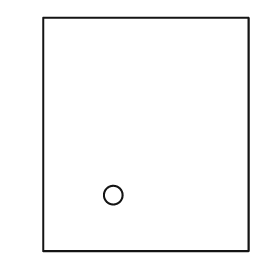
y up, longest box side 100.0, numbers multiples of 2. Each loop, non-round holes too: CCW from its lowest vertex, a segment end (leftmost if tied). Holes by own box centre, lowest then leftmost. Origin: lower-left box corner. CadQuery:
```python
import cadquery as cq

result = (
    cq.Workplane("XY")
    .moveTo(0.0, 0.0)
    .lineTo(88.0, 0.0)
    .lineTo(88.0, 100.0)
    .lineTo(0.0, 100.0)
    .close()
    .moveTo(30.0, 24.0)
    .circle(4.0)
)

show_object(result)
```